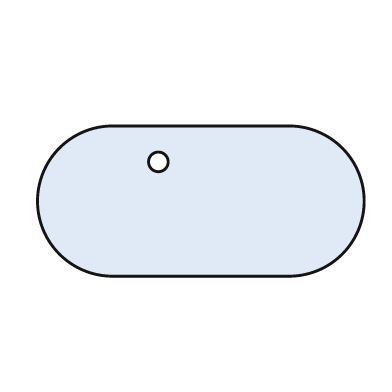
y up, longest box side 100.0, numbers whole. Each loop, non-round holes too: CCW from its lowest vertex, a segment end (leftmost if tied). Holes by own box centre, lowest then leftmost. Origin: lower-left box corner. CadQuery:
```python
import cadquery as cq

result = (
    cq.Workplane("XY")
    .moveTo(23.0, 0.0)
    .lineTo(77.0, 0.0)
    .threePointArc((100.0, 23.0), (77.0, 46.0))
    .lineTo(23.0, 46.0)
    .threePointArc((0.0, 23.0), (23.0, 0.0))
    .close()
    .moveTo(37.0, 35.0)
    .circle(3.0)
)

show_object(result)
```